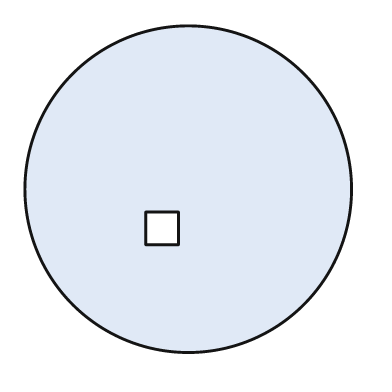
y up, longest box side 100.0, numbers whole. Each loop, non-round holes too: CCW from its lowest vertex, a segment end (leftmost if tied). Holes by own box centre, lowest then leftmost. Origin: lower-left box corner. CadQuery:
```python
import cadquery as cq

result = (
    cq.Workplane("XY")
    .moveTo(50.0, 50.0)
    .circle(50.0)
    .moveTo(37.0, 33.0)
    .lineTo(47.0, 33.0)
    .lineTo(47.0, 43.0)
    .lineTo(37.0, 43.0)
    .close()
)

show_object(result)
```